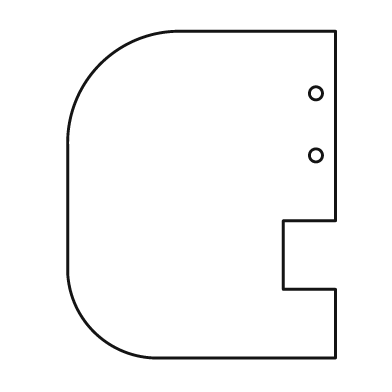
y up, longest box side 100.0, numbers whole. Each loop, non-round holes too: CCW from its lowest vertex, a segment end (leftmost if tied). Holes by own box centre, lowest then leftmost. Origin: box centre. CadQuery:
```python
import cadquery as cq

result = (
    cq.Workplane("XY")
    .moveTo(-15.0, -50.0)
    .lineTo(41.0, -50.0)
    .lineTo(41.0, -29.0)
    .lineTo(25.0, -29.0)
    .lineTo(25.0, -8.0)
    .lineTo(41.0, -8.0)
    .lineTo(41.0, 50.0)
    .lineTo(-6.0, 50.0)
    .threePointArc((-31.0, 40.0), (-41.0, 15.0))
    .lineTo(-41.0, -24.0)
    .threePointArc((-33.0, -42.0), (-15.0, -50.0))
    .close()
    .moveTo(35.0, 12.0)
    .circle(2.0)
    .moveTo(35.0, 31.0)
    .circle(2.0)
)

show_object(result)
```